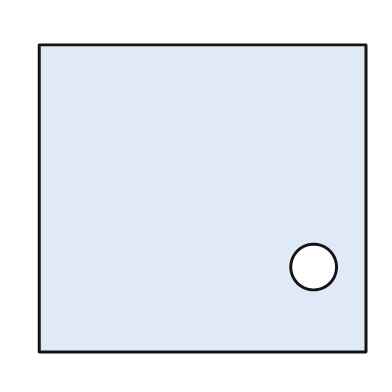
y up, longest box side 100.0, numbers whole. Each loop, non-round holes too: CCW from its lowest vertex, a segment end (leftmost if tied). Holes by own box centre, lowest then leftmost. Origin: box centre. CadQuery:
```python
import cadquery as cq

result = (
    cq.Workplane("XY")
    .moveTo(-50.0, -47.0)
    .lineTo(50.0, -47.0)
    .lineTo(50.0, 47.0)
    .lineTo(-50.0, 47.0)
    .close()
    .moveTo(34.0, -21.0)
    .circle(7.0)
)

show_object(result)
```